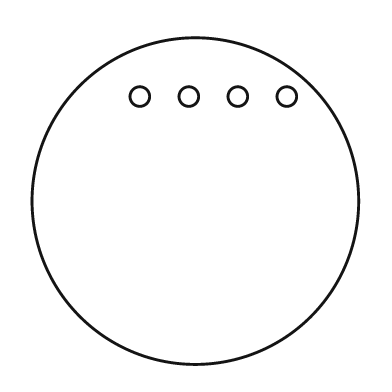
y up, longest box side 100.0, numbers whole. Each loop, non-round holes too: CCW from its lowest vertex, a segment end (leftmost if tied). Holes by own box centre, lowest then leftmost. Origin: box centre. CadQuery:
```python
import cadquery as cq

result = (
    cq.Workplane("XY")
    .moveTo(0.0, 0.0)
    .circle(50.0)
    .moveTo(-17.0, 32.0)
    .circle(3.0)
    .moveTo(-2.0, 32.0)
    .circle(3.0)
    .moveTo(13.0, 32.0)
    .circle(3.0)
    .moveTo(28.0, 32.0)
    .circle(3.0)
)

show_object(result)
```